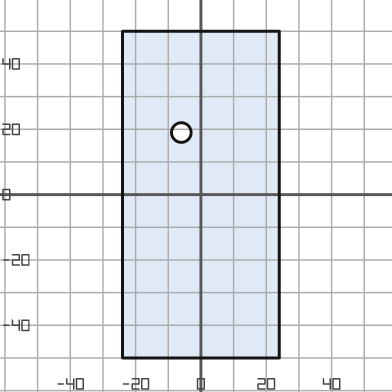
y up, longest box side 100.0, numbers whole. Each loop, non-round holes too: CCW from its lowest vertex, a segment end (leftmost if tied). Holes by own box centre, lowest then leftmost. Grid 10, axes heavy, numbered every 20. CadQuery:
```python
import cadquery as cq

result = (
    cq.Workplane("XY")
    .moveTo(-24.0, -50.0)
    .lineTo(24.0, -50.0)
    .lineTo(24.0, 50.0)
    .lineTo(-24.0, 50.0)
    .close()
    .moveTo(-6.0, 19.0)
    .circle(3.0)
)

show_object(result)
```